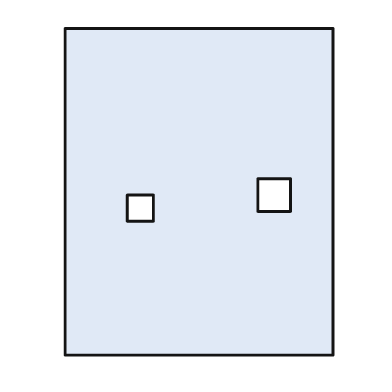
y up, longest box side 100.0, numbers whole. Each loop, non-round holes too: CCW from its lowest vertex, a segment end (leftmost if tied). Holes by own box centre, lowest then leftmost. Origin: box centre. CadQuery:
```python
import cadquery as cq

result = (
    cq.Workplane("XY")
    .moveTo(-41.0, -50.0)
    .lineTo(41.0, -50.0)
    .lineTo(41.0, 50.0)
    .lineTo(-41.0, 50.0)
    .close()
    .moveTo(-22.0, -9.0)
    .lineTo(-14.0, -9.0)
    .lineTo(-14.0, -1.0)
    .lineTo(-22.0, -1.0)
    .close()
    .moveTo(18.0, -6.0)
    .lineTo(28.0, -6.0)
    .lineTo(28.0, 4.0)
    .lineTo(18.0, 4.0)
    .close()
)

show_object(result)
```